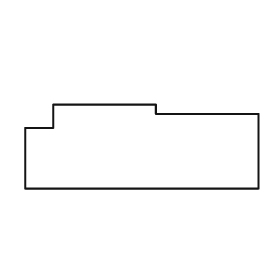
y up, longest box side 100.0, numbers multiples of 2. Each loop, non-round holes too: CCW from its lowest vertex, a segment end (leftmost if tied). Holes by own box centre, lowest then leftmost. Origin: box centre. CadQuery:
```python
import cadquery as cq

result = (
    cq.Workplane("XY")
    .moveTo(-50.0, -18.0)
    .lineTo(50.0, -18.0)
    .lineTo(50.0, 14.0)
    .lineTo(6.0, 14.0)
    .lineTo(6.0, 18.0)
    .lineTo(-38.0, 18.0)
    .lineTo(-38.0, 8.0)
    .lineTo(-50.0, 8.0)
    .close()
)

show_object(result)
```